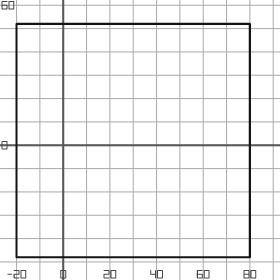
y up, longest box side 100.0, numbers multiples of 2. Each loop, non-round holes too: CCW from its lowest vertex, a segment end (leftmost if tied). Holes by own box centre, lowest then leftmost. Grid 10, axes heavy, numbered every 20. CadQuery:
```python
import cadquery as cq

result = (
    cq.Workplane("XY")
    .moveTo(-20.0, -48.0)
    .lineTo(80.0, -48.0)
    .lineTo(80.0, 52.0)
    .lineTo(-20.0, 52.0)
    .close()
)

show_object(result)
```